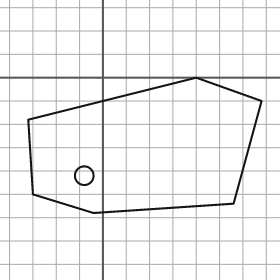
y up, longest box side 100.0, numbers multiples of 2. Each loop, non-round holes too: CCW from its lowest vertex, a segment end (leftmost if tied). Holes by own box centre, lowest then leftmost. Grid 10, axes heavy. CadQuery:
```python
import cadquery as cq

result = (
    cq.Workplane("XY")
    .moveTo(-4.0, -58.0)
    .lineTo(56.0, -54.0)
    .lineTo(68.0, -10.0)
    .lineTo(40.0, 0.0)
    .lineTo(-32.0, -18.0)
    .lineTo(-30.0, -50.0)
    .close()
    .moveTo(-8.0, -42.0)
    .circle(4.0)
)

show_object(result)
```